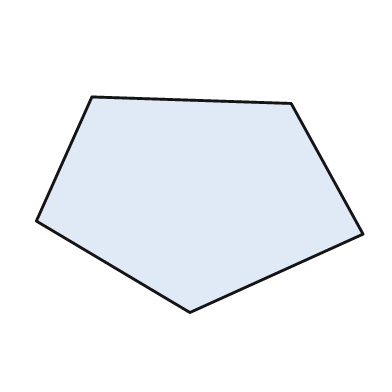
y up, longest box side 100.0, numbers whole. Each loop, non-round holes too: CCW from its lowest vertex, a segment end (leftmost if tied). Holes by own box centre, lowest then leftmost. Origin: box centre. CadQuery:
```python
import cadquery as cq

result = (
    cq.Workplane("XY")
    .moveTo(-3.0, -33.0)
    .lineTo(50.0, -9.0)
    .lineTo(28.0, 31.0)
    .lineTo(-33.0, 33.0)
    .lineTo(-50.0, -5.0)
    .close()
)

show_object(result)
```